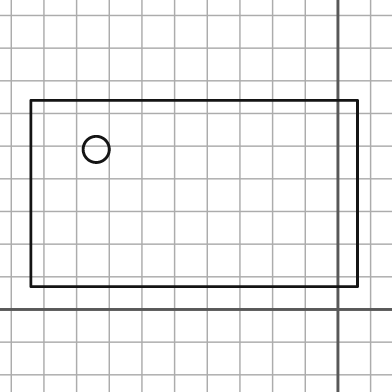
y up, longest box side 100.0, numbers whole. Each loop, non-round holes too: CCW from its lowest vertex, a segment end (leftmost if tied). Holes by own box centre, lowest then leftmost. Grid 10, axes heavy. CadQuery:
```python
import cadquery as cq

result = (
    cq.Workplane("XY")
    .moveTo(-94.0, 7.0)
    .lineTo(6.0, 7.0)
    .lineTo(6.0, 64.0)
    .lineTo(-94.0, 64.0)
    .close()
    .moveTo(-74.0, 49.0)
    .circle(4.0)
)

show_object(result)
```